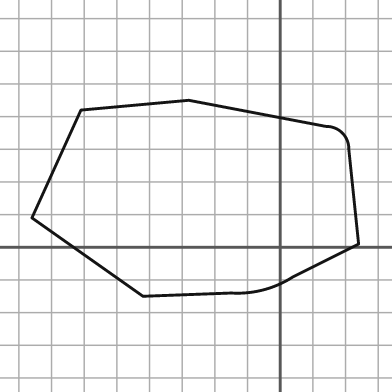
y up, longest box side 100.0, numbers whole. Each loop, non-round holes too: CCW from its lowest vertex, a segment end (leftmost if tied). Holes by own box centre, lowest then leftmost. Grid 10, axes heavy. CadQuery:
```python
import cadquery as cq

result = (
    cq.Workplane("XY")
    .moveTo(-42.0, -15.0)
    .lineTo(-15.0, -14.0)
    .threePointArc((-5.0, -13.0), (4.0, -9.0))
    .lineTo(24.0, 1.0)
    .lineTo(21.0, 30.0)
    .threePointArc((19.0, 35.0), (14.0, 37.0))
    .lineTo(-28.0, 45.0)
    .lineTo(-61.0, 42.0)
    .lineTo(-76.0, 9.0)
    .close()
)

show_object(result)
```